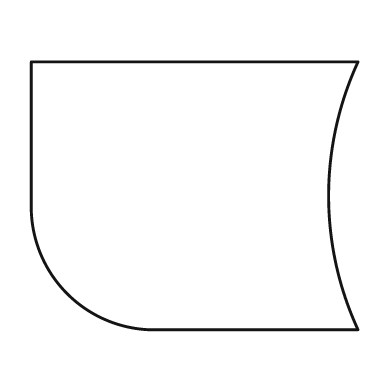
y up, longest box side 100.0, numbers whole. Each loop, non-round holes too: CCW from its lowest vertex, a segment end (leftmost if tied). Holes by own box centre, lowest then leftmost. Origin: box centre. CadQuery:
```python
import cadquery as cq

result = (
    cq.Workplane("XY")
    .moveTo(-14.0, -41.0)
    .lineTo(50.0, -41.0)
    .threePointArc((41.0, 0.0), (50.0, 41.0))
    .lineTo(-50.0, 41.0)
    .lineTo(-50.0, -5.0)
    .threePointArc((-39.0, -30.0), (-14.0, -41.0))
    .close()
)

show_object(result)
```